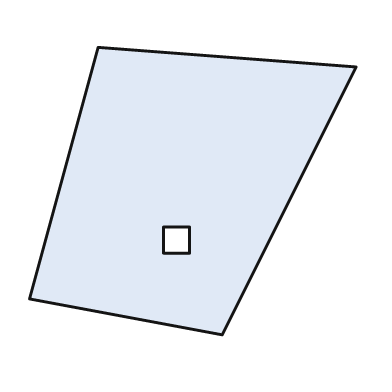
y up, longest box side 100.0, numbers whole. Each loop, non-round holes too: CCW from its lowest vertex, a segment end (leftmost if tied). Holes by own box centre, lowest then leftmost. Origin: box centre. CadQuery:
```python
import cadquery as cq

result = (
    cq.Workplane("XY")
    .moveTo(9.0, -44.0)
    .lineTo(50.0, 38.0)
    .lineTo(-29.0, 44.0)
    .lineTo(-50.0, -33.0)
    .close()
    .moveTo(-9.0, -19.0)
    .lineTo(-1.0, -19.0)
    .lineTo(-1.0, -11.0)
    .lineTo(-9.0, -11.0)
    .close()
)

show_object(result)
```